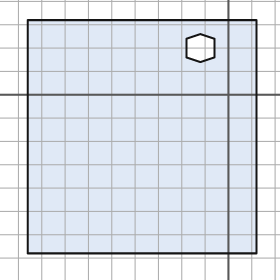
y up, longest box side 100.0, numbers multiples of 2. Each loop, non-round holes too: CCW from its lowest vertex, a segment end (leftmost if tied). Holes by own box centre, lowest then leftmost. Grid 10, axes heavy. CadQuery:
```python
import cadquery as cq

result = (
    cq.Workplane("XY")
    .moveTo(-86.0, -68.0)
    .lineTo(12.0, -68.0)
    .lineTo(12.0, 32.0)
    .lineTo(-86.0, 32.0)
    .close()
    .moveTo(-12.0, 14.0)
    .lineTo(-6.0, 16.0)
    .lineTo(-6.0, 24.0)
    .lineTo(-12.0, 26.0)
    .lineTo(-18.0, 24.0)
    .lineTo(-18.0, 16.0)
    .close()
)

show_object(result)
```